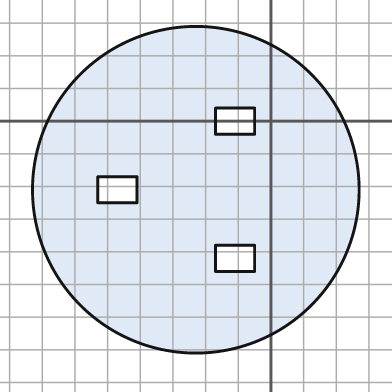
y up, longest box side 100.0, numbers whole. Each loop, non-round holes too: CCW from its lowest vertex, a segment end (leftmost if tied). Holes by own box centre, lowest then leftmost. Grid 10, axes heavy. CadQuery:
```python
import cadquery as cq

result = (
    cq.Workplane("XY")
    .moveTo(-23.0, -21.0)
    .circle(50.0)
    .moveTo(-17.0, -46.0)
    .lineTo(-5.0, -46.0)
    .lineTo(-5.0, -38.0)
    .lineTo(-17.0, -38.0)
    .close()
    .moveTo(-53.0, -25.0)
    .lineTo(-41.0, -25.0)
    .lineTo(-41.0, -17.0)
    .lineTo(-53.0, -17.0)
    .close()
    .moveTo(-17.0, -4.0)
    .lineTo(-5.0, -4.0)
    .lineTo(-5.0, 4.0)
    .lineTo(-17.0, 4.0)
    .close()
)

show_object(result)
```